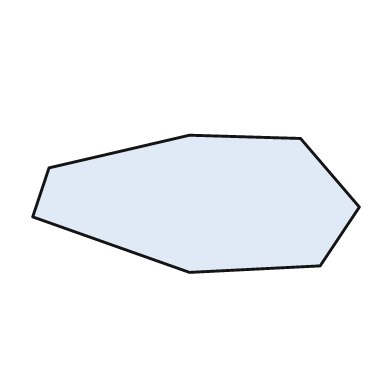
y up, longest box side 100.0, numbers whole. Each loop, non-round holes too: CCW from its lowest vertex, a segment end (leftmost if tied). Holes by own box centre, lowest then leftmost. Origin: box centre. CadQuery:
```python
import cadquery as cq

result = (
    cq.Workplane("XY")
    .moveTo(-2.0, -21.0)
    .lineTo(38.0, -19.0)
    .lineTo(50.0, -1.0)
    .lineTo(32.0, 20.0)
    .lineTo(-2.0, 21.0)
    .lineTo(-45.0, 11.0)
    .lineTo(-50.0, -4.0)
    .close()
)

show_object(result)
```